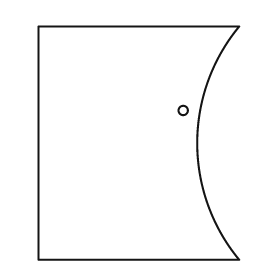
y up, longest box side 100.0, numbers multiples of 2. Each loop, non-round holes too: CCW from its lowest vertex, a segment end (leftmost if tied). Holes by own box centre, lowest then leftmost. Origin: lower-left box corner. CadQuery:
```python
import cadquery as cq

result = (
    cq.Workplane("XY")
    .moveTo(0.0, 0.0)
    .lineTo(86.0, 0.0)
    .threePointArc((68.0, 50.0), (86.0, 100.0))
    .lineTo(0.0, 100.0)
    .close()
    .moveTo(62.0, 64.0)
    .circle(2.0)
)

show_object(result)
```